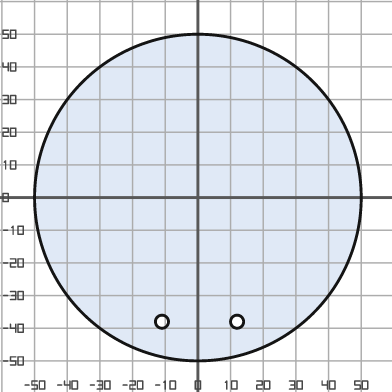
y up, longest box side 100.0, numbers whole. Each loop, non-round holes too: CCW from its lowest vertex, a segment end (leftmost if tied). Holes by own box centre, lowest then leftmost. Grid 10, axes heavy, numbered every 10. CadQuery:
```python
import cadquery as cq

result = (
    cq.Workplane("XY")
    .moveTo(0.0, 0.0)
    .circle(50.0)
    .moveTo(-11.0, -38.0)
    .circle(2.0)
    .moveTo(12.0, -38.0)
    .circle(2.0)
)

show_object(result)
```